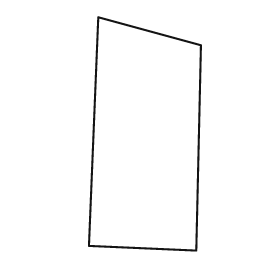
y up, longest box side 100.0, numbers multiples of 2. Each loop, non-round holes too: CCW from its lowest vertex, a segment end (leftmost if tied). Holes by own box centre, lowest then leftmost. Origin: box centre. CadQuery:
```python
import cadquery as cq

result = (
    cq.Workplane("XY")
    .moveTo(22.0, -50.0)
    .lineTo(24.0, 38.0)
    .lineTo(-20.0, 50.0)
    .lineTo(-24.0, -48.0)
    .close()
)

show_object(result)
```